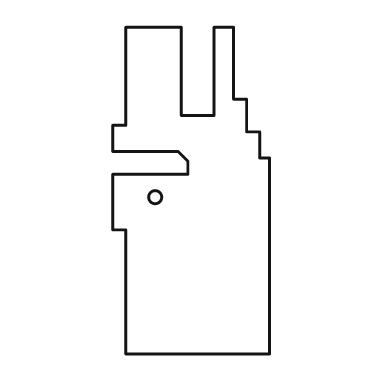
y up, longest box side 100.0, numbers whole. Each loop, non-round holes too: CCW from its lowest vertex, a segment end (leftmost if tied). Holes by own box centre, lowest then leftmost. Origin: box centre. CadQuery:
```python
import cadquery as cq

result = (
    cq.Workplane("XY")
    .moveTo(-20.0, -50.0)
    .lineTo(24.0, -50.0)
    .lineTo(24.0, 10.0)
    .lineTo(21.0, 10.0)
    .lineTo(21.0, 18.0)
    .lineTo(17.0, 18.0)
    .lineTo(17.0, 28.0)
    .lineTo(13.0, 28.0)
    .lineTo(13.0, 50.0)
    .lineTo(7.0, 50.0)
    .lineTo(7.0, 23.0)
    .lineTo(-3.0, 23.0)
    .lineTo(-3.0, 50.0)
    .lineTo(-20.0, 50.0)
    .lineTo(-20.0, 20.0)
    .lineTo(-24.0, 20.0)
    .lineTo(-24.0, 12.0)
    .lineTo(-4.0, 12.0)
    .lineTo(-1.0, 9.0)
    .lineTo(-1.0, 5.0)
    .lineTo(-24.0, 5.0)
    .lineTo(-24.0, -12.0)
    .lineTo(-20.0, -12.0)
    .close()
    .moveTo(-11.0, -2.0)
    .circle(2.0)
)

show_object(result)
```